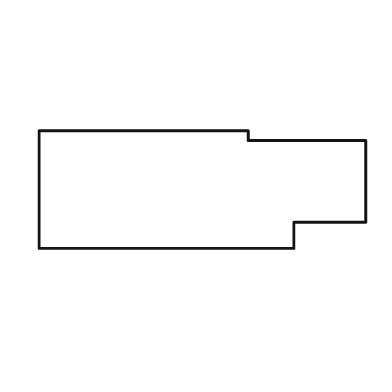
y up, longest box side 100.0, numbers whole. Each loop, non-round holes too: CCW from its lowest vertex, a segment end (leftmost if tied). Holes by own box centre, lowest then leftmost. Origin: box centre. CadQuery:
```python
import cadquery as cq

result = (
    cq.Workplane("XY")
    .moveTo(-50.0, -18.0)
    .lineTo(28.0, -18.0)
    .lineTo(28.0, -10.0)
    .lineTo(50.0, -10.0)
    .lineTo(50.0, 15.0)
    .lineTo(14.0, 15.0)
    .lineTo(14.0, 18.0)
    .lineTo(-50.0, 18.0)
    .close()
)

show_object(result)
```